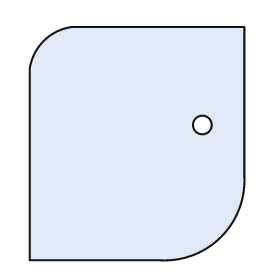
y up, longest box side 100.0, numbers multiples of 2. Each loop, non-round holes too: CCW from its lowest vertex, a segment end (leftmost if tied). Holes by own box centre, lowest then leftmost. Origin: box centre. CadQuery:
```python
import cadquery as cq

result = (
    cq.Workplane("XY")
    .moveTo(-46.0, -50.0)
    .lineTo(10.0, -50.0)
    .threePointArc((36.0, -40.0), (46.0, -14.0))
    .lineTo(46.0, 50.0)
    .lineTo(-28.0, 50.0)
    .threePointArc((-40.0, 44.0), (-46.0, 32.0))
    .close()
    .moveTo(28.0, 8.0)
    .circle(4.0)
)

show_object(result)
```